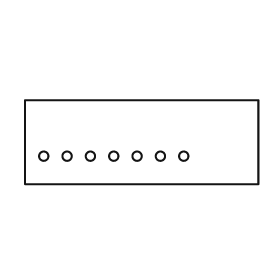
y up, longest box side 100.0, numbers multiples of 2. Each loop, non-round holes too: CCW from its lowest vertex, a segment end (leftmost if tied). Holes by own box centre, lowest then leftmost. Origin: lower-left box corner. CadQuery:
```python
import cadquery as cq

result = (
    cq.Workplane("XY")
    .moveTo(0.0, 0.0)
    .lineTo(100.0, 0.0)
    .lineTo(100.0, 36.0)
    .lineTo(0.0, 36.0)
    .close()
    .moveTo(8.0, 12.0)
    .circle(2.0)
    .moveTo(18.0, 12.0)
    .circle(2.0)
    .moveTo(28.0, 12.0)
    .circle(2.0)
    .moveTo(38.0, 12.0)
    .circle(2.0)
    .moveTo(48.0, 12.0)
    .circle(2.0)
    .moveTo(58.0, 12.0)
    .circle(2.0)
    .moveTo(68.0, 12.0)
    .circle(2.0)
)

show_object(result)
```